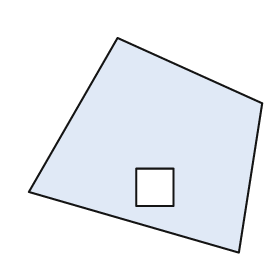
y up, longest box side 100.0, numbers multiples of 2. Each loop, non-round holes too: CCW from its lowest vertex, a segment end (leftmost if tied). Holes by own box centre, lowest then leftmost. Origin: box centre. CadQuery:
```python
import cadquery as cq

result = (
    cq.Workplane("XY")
    .moveTo(40.0, -46.0)
    .lineTo(50.0, 18.0)
    .lineTo(-12.0, 46.0)
    .lineTo(-50.0, -20.0)
    .close()
    .moveTo(-4.0, -26.0)
    .lineTo(12.0, -26.0)
    .lineTo(12.0, -10.0)
    .lineTo(-4.0, -10.0)
    .close()
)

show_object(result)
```